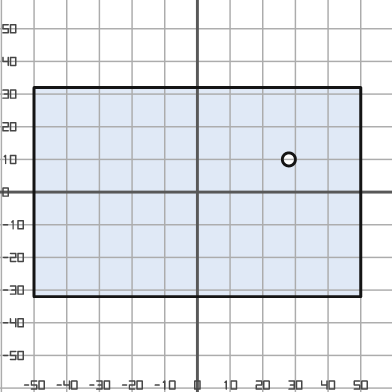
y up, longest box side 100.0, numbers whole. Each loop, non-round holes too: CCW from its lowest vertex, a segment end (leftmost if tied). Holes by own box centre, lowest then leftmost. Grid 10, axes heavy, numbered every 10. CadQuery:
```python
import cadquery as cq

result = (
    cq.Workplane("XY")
    .moveTo(-50.0, -32.0)
    .lineTo(50.0, -32.0)
    .lineTo(50.0, 32.0)
    .lineTo(-50.0, 32.0)
    .close()
    .moveTo(28.0, 10.0)
    .circle(2.0)
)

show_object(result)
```